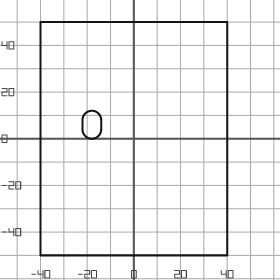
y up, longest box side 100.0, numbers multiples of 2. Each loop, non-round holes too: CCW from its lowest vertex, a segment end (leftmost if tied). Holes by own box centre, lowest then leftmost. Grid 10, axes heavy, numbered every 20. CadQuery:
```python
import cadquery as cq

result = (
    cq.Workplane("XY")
    .moveTo(-40.0, -50.0)
    .lineTo(40.0, -50.0)
    .lineTo(40.0, 50.0)
    .lineTo(-40.0, 50.0)
    .close()
    .moveTo(-22.0, 4.0)
    .threePointArc((-18.0, 0.0), (-14.0, 4.0))
    .lineTo(-14.0, 8.0)
    .threePointArc((-18.0, 12.0), (-22.0, 8.0))
    .close()
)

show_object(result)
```